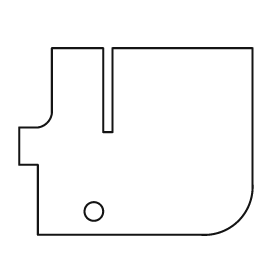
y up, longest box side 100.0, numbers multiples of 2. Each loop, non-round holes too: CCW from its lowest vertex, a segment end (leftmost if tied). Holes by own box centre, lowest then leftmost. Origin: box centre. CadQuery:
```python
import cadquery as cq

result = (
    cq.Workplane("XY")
    .moveTo(-42.0, -40.0)
    .lineTo(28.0, -40.0)
    .threePointArc((44.0, -34.0), (50.0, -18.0))
    .lineTo(50.0, 40.0)
    .lineTo(-10.0, 40.0)
    .lineTo(-10.0, 4.0)
    .lineTo(-14.0, 4.0)
    .lineTo(-14.0, 40.0)
    .lineTo(-36.0, 40.0)
    .lineTo(-36.0, 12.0)
    .threePointArc((-38.0, 8.0), (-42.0, 6.0))
    .lineTo(-50.0, 6.0)
    .lineTo(-50.0, -10.0)
    .lineTo(-42.0, -10.0)
    .close()
    .moveTo(-18.0, -30.0)
    .circle(4.0)
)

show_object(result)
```